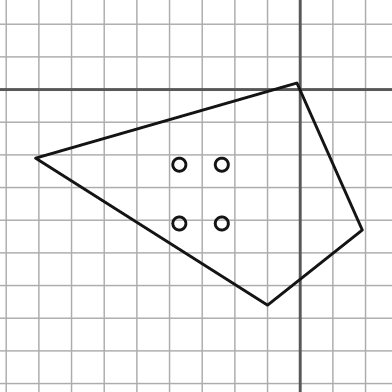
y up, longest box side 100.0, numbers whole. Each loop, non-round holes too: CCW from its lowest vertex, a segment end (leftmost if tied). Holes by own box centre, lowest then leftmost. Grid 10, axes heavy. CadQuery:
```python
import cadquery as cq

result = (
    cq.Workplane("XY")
    .moveTo(-10.0, -66.0)
    .lineTo(19.0, -43.0)
    .lineTo(-1.0, 2.0)
    .lineTo(-81.0, -21.0)
    .close()
    .moveTo(-37.0, -41.0)
    .circle(2.0)
    .moveTo(-24.0, -41.0)
    .circle(2.0)
    .moveTo(-37.0, -23.0)
    .circle(2.0)
    .moveTo(-24.0, -23.0)
    .circle(2.0)
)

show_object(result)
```